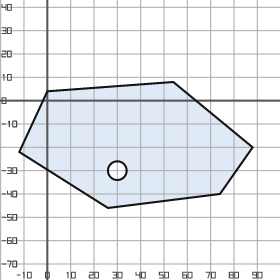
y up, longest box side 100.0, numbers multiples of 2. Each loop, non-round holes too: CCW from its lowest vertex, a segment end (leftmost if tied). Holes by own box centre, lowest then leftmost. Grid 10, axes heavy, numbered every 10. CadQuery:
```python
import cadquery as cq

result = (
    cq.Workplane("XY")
    .moveTo(26.0, -46.0)
    .lineTo(74.0, -40.0)
    .lineTo(88.0, -20.0)
    .lineTo(54.0, 8.0)
    .lineTo(0.0, 4.0)
    .lineTo(-12.0, -22.0)
    .close()
    .moveTo(30.0, -30.0)
    .circle(4.0)
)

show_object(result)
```